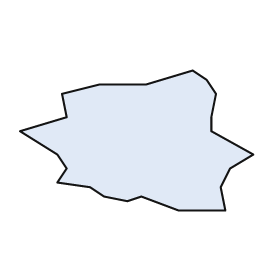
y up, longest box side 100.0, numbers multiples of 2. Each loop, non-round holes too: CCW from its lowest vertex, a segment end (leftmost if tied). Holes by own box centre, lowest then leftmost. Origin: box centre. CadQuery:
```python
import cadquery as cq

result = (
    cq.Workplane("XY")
    .moveTo(18.0, -30.0)
    .lineTo(38.0, -30.0)
    .lineTo(36.0, -20.0)
    .lineTo(40.0, -12.0)
    .lineTo(50.0, -6.0)
    .lineTo(32.0, 4.0)
    .lineTo(32.0, 10.0)
    .lineTo(34.0, 20.0)
    .lineTo(30.0, 26.0)
    .lineTo(24.0, 30.0)
    .lineTo(4.0, 24.0)
    .lineTo(-16.0, 24.0)
    .lineTo(-32.0, 20.0)
    .lineTo(-30.0, 10.0)
    .lineTo(-50.0, 4.0)
    .lineTo(-34.0, -6.0)
    .lineTo(-30.0, -12.0)
    .lineTo(-34.0, -18.0)
    .lineTo(-20.0, -20.0)
    .lineTo(-14.0, -24.0)
    .lineTo(-4.0, -26.0)
    .lineTo(2.0, -24.0)
    .close()
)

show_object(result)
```